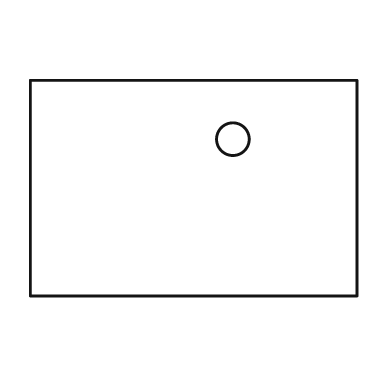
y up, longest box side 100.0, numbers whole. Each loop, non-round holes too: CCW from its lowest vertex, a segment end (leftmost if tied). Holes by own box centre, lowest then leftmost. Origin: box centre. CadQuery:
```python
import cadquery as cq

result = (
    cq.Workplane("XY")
    .moveTo(-50.0, -33.0)
    .lineTo(50.0, -33.0)
    .lineTo(50.0, 33.0)
    .lineTo(-50.0, 33.0)
    .close()
    .moveTo(12.0, 15.0)
    .circle(5.0)
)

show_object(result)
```